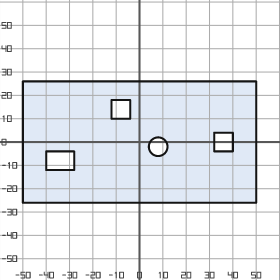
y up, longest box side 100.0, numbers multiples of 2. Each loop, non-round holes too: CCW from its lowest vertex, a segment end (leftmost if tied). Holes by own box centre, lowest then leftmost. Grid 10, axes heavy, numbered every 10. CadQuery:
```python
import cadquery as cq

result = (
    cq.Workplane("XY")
    .moveTo(-50.0, -26.0)
    .lineTo(50.0, -26.0)
    .lineTo(50.0, 26.0)
    .lineTo(-50.0, 26.0)
    .close()
    .moveTo(-40.0, -12.0)
    .lineTo(-28.0, -12.0)
    .lineTo(-28.0, -4.0)
    .lineTo(-40.0, -4.0)
    .close()
    .moveTo(8.0, -2.0)
    .circle(4.0)
    .moveTo(32.0, -4.0)
    .lineTo(40.0, -4.0)
    .lineTo(40.0, 4.0)
    .lineTo(32.0, 4.0)
    .close()
    .moveTo(-12.0, 10.0)
    .lineTo(-4.0, 10.0)
    .lineTo(-4.0, 18.0)
    .lineTo(-12.0, 18.0)
    .close()
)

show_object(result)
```